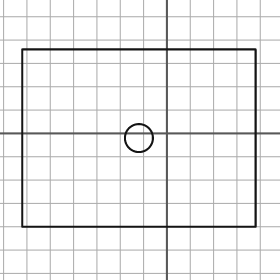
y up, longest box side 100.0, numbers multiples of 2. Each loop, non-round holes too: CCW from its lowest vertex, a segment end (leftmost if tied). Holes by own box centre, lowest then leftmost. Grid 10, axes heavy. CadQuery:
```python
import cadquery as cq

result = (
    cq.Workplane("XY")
    .moveTo(-62.0, -40.0)
    .lineTo(38.0, -40.0)
    .lineTo(38.0, 36.0)
    .lineTo(-62.0, 36.0)
    .close()
    .moveTo(-12.0, -2.0)
    .circle(6.0)
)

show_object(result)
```